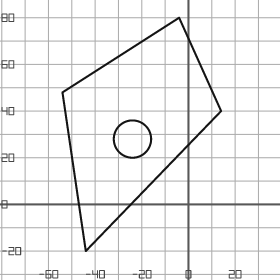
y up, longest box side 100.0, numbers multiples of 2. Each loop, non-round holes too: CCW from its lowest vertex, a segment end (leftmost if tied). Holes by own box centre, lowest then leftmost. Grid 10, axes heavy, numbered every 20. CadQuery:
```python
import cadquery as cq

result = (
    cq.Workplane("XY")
    .moveTo(-44.0, -20.0)
    .lineTo(14.0, 40.0)
    .lineTo(-4.0, 80.0)
    .lineTo(-54.0, 48.0)
    .close()
    .moveTo(-24.0, 28.0)
    .circle(8.0)
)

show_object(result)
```